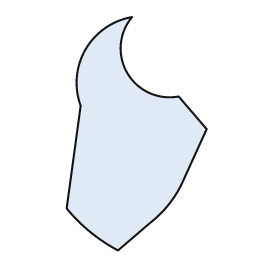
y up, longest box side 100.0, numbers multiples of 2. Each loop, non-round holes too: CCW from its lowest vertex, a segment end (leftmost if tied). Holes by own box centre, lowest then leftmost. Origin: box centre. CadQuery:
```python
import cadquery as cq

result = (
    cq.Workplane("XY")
    .moveTo(-8.0, -50.0)
    .lineTo(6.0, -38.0)
    .threePointArc((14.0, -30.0), (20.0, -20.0))
    .lineTo(30.0, 2.0)
    .lineTo(18.0, 16.0)
    .threePointArc((-4.0, 26.0), (-2.0, 50.0))
    .threePointArc((-22.0, 36.0), (-24.0, 12.0))
    .lineTo(-30.0, -32.0)
    .threePointArc((-20.0, -42.0), (-8.0, -50.0))
    .close()
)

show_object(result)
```